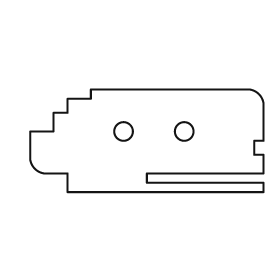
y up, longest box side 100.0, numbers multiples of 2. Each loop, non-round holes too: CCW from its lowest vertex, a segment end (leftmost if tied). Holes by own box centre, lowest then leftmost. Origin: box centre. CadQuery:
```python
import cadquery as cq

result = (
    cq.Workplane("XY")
    .moveTo(-34.0, -22.0)
    .lineTo(50.0, -22.0)
    .lineTo(50.0, -18.0)
    .lineTo(0.0, -18.0)
    .lineTo(0.0, -14.0)
    .lineTo(50.0, -14.0)
    .lineTo(50.0, -6.0)
    .lineTo(46.0, -6.0)
    .lineTo(46.0, 0.0)
    .lineTo(50.0, 0.0)
    .lineTo(50.0, 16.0)
    .threePointArc((48.0, 20.0), (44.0, 22.0))
    .lineTo(-24.0, 22.0)
    .lineTo(-24.0, 18.0)
    .lineTo(-34.0, 18.0)
    .lineTo(-34.0, 12.0)
    .lineTo(-40.0, 12.0)
    .lineTo(-40.0, 4.0)
    .lineTo(-50.0, 4.0)
    .lineTo(-50.0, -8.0)
    .threePointArc((-48.0, -12.0), (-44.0, -14.0))
    .lineTo(-34.0, -14.0)
    .close()
    .moveTo(-10.0, 4.0)
    .circle(4.0)
    .moveTo(16.0, 4.0)
    .circle(4.0)
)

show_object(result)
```